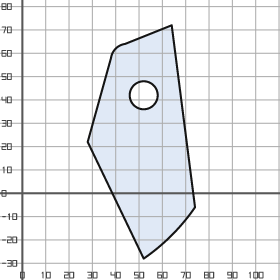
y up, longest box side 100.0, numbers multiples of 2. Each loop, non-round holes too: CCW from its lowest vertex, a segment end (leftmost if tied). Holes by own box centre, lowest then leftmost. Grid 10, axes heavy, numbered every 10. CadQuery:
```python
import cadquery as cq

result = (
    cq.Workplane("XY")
    .moveTo(52.0, -28.0)
    .threePointArc((64.0, -18.0), (74.0, -6.0))
    .lineTo(64.0, 72.0)
    .lineTo(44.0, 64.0)
    .threePointArc((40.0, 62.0), (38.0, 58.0))
    .lineTo(28.0, 22.0)
    .close()
    .moveTo(52.0, 42.0)
    .circle(6.0)
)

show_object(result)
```